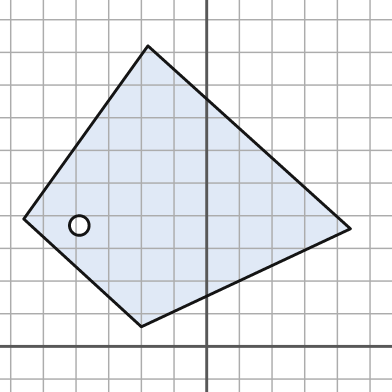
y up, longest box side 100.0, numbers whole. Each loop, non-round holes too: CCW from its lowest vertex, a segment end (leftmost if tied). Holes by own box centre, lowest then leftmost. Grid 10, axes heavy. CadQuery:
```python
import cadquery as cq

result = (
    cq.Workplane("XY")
    .moveTo(-20.0, 6.0)
    .lineTo(44.0, 36.0)
    .lineTo(-18.0, 92.0)
    .lineTo(-56.0, 39.0)
    .close()
    .moveTo(-39.0, 37.0)
    .circle(3.0)
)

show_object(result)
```